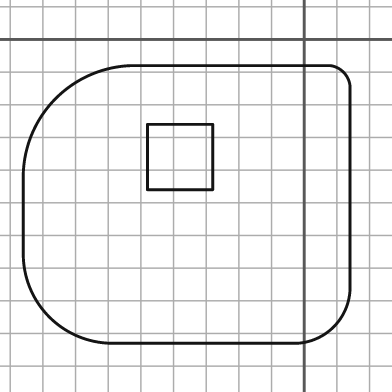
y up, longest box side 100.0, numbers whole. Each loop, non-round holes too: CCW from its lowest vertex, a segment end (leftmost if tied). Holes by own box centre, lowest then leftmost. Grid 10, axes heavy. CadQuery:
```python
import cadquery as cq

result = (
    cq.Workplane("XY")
    .moveTo(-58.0, -93.0)
    .lineTo(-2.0, -93.0)
    .threePointArc((9.0, -88.0), (14.0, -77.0))
    .lineTo(14.0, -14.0)
    .threePointArc((12.0, -10.0), (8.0, -8.0))
    .lineTo(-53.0, -8.0)
    .threePointArc((-76.0, -18.0), (-86.0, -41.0))
    .lineTo(-86.0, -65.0)
    .threePointArc((-78.0, -85.0), (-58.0, -93.0))
    .close()
    .moveTo(-48.0, -46.0)
    .lineTo(-28.0, -46.0)
    .lineTo(-28.0, -26.0)
    .lineTo(-48.0, -26.0)
    .close()
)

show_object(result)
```